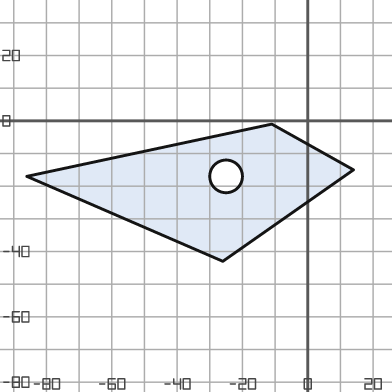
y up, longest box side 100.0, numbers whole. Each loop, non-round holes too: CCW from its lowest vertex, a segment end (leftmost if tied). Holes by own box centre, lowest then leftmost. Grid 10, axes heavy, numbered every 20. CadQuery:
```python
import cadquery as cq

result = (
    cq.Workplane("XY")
    .moveTo(-26.0, -43.0)
    .lineTo(14.0, -15.0)
    .lineTo(-11.0, -1.0)
    .lineTo(-86.0, -17.0)
    .close()
    .moveTo(-25.0, -17.0)
    .circle(5.0)
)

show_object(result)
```